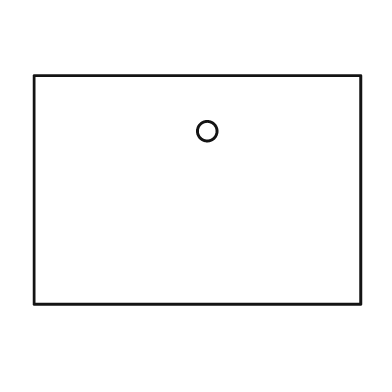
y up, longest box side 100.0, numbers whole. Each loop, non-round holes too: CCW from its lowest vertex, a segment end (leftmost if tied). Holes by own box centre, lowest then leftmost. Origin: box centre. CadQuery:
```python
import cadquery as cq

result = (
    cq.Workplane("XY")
    .moveTo(-50.0, -35.0)
    .lineTo(50.0, -35.0)
    .lineTo(50.0, 35.0)
    .lineTo(-50.0, 35.0)
    .close()
    .moveTo(3.0, 18.0)
    .circle(3.0)
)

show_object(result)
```